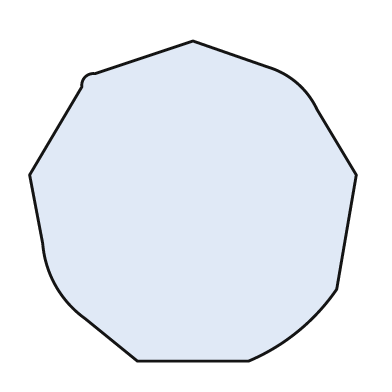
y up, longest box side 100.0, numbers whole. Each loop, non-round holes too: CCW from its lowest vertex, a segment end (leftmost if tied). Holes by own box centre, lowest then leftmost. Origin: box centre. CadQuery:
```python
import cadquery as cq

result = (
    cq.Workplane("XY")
    .moveTo(-17.0, -49.0)
    .lineTo(17.0, -49.0)
    .threePointArc((32.0, -40.0), (44.0, -27.0))
    .lineTo(50.0, 8.0)
    .lineTo(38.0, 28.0)
    .threePointArc((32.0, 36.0), (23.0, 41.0))
    .lineTo(0.0, 49.0)
    .lineTo(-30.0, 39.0)
    .threePointArc((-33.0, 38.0), (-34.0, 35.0))
    .lineTo(-50.0, 8.0)
    .lineTo(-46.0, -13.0)
    .threePointArc((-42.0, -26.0), (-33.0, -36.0))
    .close()
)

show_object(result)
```